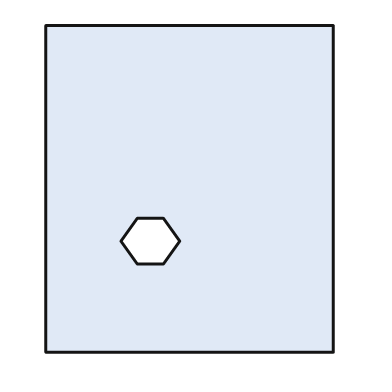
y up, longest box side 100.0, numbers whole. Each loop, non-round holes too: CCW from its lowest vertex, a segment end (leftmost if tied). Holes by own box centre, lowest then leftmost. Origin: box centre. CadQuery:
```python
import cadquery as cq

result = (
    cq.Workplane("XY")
    .moveTo(-44.0, -50.0)
    .lineTo(44.0, -50.0)
    .lineTo(44.0, 50.0)
    .lineTo(-44.0, 50.0)
    .close()
    .moveTo(-16.0, -23.0)
    .lineTo(-8.0, -23.0)
    .lineTo(-3.0, -16.0)
    .lineTo(-8.0, -9.0)
    .lineTo(-16.0, -9.0)
    .lineTo(-21.0, -16.0)
    .close()
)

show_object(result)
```